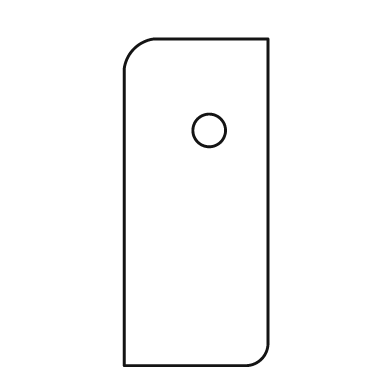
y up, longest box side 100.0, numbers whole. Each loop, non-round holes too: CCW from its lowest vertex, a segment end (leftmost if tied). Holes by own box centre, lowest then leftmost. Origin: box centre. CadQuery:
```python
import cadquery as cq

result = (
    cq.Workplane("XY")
    .moveTo(-22.0, -50.0)
    .lineTo(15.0, -50.0)
    .threePointArc((20.0, -48.0), (22.0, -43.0))
    .lineTo(22.0, 50.0)
    .lineTo(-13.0, 50.0)
    .threePointArc((-19.0, 47.0), (-22.0, 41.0))
    .close()
    .moveTo(4.0, 22.0)
    .circle(5.0)
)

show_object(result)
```